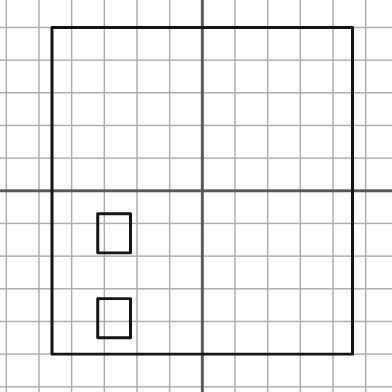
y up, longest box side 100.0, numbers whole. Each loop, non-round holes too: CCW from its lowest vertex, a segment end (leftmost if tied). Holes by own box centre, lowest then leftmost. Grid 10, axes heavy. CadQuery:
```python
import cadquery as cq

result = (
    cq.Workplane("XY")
    .moveTo(-46.0, -50.0)
    .lineTo(46.0, -50.0)
    .lineTo(46.0, 50.0)
    .lineTo(-46.0, 50.0)
    .close()
    .moveTo(-32.0, -45.0)
    .lineTo(-22.0, -45.0)
    .lineTo(-22.0, -33.0)
    .lineTo(-32.0, -33.0)
    .close()
    .moveTo(-32.0, -19.0)
    .lineTo(-22.0, -19.0)
    .lineTo(-22.0, -7.0)
    .lineTo(-32.0, -7.0)
    .close()
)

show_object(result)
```